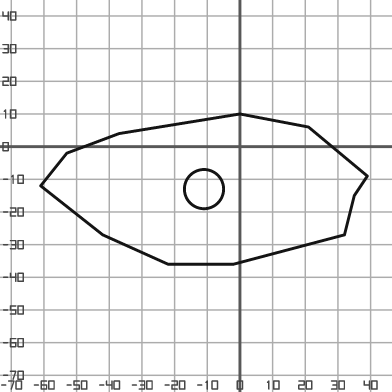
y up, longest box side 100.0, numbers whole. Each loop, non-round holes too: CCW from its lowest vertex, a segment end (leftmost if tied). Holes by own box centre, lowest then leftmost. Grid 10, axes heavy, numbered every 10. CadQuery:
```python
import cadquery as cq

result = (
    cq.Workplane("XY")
    .moveTo(-22.0, -36.0)
    .lineTo(-2.0, -36.0)
    .lineTo(32.0, -27.0)
    .lineTo(35.0, -15.0)
    .lineTo(39.0, -9.0)
    .lineTo(21.0, 6.0)
    .lineTo(0.0, 10.0)
    .lineTo(-37.0, 4.0)
    .lineTo(-53.0, -2.0)
    .lineTo(-61.0, -12.0)
    .lineTo(-42.0, -27.0)
    .close()
    .moveTo(-11.0, -13.0)
    .circle(6.0)
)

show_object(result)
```